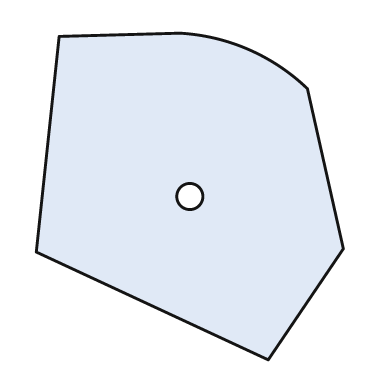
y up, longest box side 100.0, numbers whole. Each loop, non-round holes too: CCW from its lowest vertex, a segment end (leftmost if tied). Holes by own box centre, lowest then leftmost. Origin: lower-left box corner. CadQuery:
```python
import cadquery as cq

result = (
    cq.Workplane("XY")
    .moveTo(71.0, 0.0)
    .lineTo(94.0, 34.0)
    .lineTo(83.0, 83.0)
    .threePointArc((65.0, 95.0), (44.0, 100.0))
    .lineTo(7.0, 99.0)
    .lineTo(0.0, 33.0)
    .close()
    .moveTo(47.0, 50.0)
    .circle(4.0)
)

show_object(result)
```